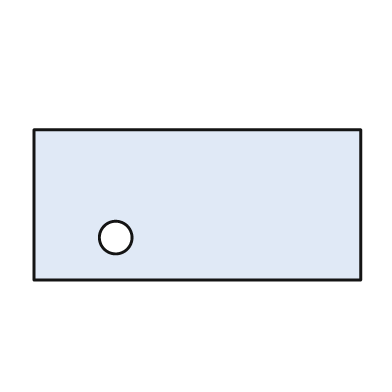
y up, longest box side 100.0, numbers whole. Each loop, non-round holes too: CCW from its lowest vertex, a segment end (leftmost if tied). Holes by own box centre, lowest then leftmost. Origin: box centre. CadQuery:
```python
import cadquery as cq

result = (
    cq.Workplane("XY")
    .moveTo(-50.0, -23.0)
    .lineTo(50.0, -23.0)
    .lineTo(50.0, 23.0)
    .lineTo(-50.0, 23.0)
    .close()
    .moveTo(-25.0, -10.0)
    .circle(5.0)
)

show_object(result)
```